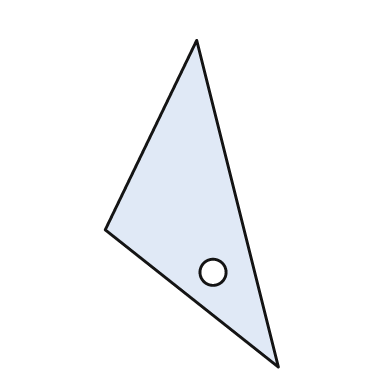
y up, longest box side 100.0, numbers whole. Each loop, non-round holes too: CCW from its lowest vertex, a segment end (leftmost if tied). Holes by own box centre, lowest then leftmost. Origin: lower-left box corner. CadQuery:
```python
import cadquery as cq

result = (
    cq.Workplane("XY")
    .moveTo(53.0, 0.0)
    .lineTo(28.0, 100.0)
    .lineTo(0.0, 42.0)
    .close()
    .moveTo(33.0, 29.0)
    .circle(4.0)
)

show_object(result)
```